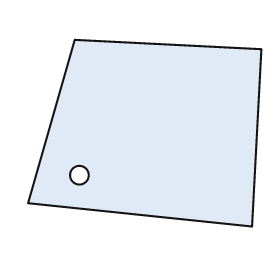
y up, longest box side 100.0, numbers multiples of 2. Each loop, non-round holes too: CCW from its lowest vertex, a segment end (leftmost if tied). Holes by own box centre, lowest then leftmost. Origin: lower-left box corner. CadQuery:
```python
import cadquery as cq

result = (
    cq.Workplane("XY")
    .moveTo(96.0, 0.0)
    .lineTo(100.0, 76.0)
    .lineTo(20.0, 80.0)
    .lineTo(0.0, 10.0)
    .close()
    .moveTo(22.0, 22.0)
    .circle(4.0)
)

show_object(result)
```